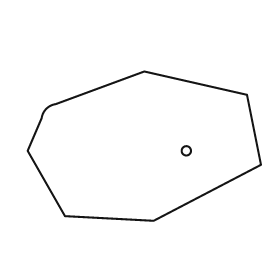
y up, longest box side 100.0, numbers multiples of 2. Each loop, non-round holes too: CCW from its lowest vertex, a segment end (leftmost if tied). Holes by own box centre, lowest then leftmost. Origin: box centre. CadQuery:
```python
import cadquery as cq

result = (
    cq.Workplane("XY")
    .moveTo(4.0, -32.0)
    .lineTo(50.0, -8.0)
    .lineTo(44.0, 22.0)
    .lineTo(0.0, 32.0)
    .lineTo(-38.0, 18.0)
    .threePointArc((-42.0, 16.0), (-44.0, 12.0))
    .lineTo(-50.0, -2.0)
    .lineTo(-34.0, -30.0)
    .close()
    .moveTo(18.0, -2.0)
    .circle(2.0)
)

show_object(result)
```